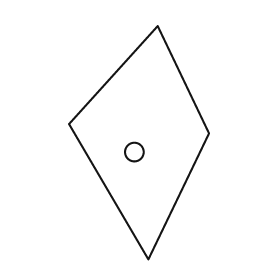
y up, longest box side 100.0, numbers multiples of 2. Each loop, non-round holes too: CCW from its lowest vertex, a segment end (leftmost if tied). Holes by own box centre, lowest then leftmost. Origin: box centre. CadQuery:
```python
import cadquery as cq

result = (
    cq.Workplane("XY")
    .moveTo(4.0, -50.0)
    .lineTo(30.0, 4.0)
    .lineTo(8.0, 50.0)
    .lineTo(-30.0, 8.0)
    .close()
    .moveTo(-2.0, -4.0)
    .circle(4.0)
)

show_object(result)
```